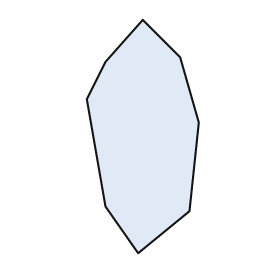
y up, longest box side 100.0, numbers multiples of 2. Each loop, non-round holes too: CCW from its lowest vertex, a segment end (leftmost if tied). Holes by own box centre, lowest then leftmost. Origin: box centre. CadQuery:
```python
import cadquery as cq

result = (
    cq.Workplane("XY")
    .moveTo(-2.0, -50.0)
    .lineTo(20.0, -32.0)
    .lineTo(24.0, 6.0)
    .lineTo(16.0, 34.0)
    .lineTo(0.0, 50.0)
    .lineTo(-16.0, 32.0)
    .lineTo(-24.0, 16.0)
    .lineTo(-16.0, -30.0)
    .close()
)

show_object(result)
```